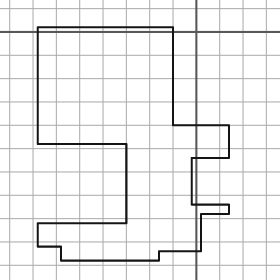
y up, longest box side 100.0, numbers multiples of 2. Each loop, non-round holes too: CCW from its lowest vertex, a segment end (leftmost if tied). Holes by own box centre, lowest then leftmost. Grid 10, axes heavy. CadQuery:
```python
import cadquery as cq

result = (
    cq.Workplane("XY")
    .moveTo(-58.0, -98.0)
    .lineTo(-16.0, -98.0)
    .lineTo(-16.0, -94.0)
    .lineTo(2.0, -94.0)
    .lineTo(2.0, -78.0)
    .lineTo(14.0, -78.0)
    .lineTo(14.0, -74.0)
    .lineTo(-2.0, -74.0)
    .lineTo(-2.0, -54.0)
    .lineTo(14.0, -54.0)
    .lineTo(14.0, -40.0)
    .lineTo(-10.0, -40.0)
    .lineTo(-10.0, 2.0)
    .lineTo(-68.0, 2.0)
    .lineTo(-68.0, -48.0)
    .lineTo(-30.0, -48.0)
    .lineTo(-30.0, -82.0)
    .lineTo(-68.0, -82.0)
    .lineTo(-68.0, -92.0)
    .lineTo(-58.0, -92.0)
    .close()
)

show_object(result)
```